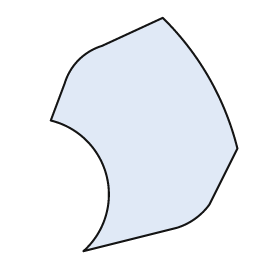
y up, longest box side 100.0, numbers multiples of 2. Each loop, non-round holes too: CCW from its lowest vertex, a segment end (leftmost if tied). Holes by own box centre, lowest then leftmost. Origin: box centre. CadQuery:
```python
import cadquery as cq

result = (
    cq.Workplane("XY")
    .moveTo(-26.0, -50.0)
    .lineTo(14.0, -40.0)
    .threePointArc((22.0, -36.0), (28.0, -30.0))
    .lineTo(40.0, -6.0)
    .threePointArc((28.0, 24.0), (8.0, 50.0))
    .lineTo(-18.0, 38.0)
    .threePointArc((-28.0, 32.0), (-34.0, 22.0))
    .lineTo(-40.0, 6.0)
    .threePointArc((-16.0, -18.0), (-26.0, -50.0))
    .close()
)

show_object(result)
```